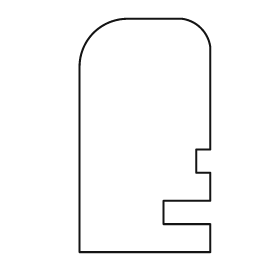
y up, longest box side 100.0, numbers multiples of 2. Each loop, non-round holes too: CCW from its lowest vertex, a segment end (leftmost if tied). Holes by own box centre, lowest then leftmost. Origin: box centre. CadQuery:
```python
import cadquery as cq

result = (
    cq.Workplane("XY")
    .moveTo(-28.0, -50.0)
    .lineTo(28.0, -50.0)
    .lineTo(28.0, -38.0)
    .lineTo(8.0, -38.0)
    .lineTo(8.0, -28.0)
    .lineTo(28.0, -28.0)
    .lineTo(28.0, -16.0)
    .lineTo(22.0, -16.0)
    .lineTo(22.0, -6.0)
    .lineTo(28.0, -6.0)
    .lineTo(28.0, 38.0)
    .threePointArc((24.0, 46.0), (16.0, 50.0))
    .lineTo(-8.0, 50.0)
    .threePointArc((-22.0, 44.0), (-28.0, 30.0))
    .close()
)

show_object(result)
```